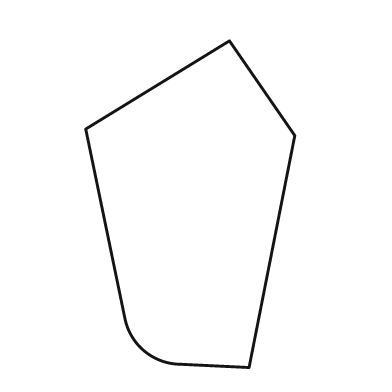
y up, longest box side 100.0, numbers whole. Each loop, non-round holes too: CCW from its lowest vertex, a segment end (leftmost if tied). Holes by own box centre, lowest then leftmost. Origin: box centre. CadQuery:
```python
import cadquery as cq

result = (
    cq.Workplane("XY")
    .moveTo(18.0, -50.0)
    .lineTo(32.0, 21.0)
    .lineTo(12.0, 50.0)
    .lineTo(-32.0, 23.0)
    .lineTo(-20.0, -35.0)
    .threePointArc((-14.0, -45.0), (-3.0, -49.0))
    .close()
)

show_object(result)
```